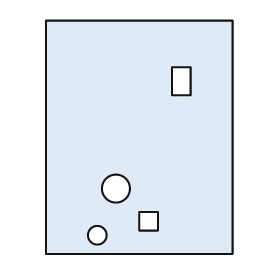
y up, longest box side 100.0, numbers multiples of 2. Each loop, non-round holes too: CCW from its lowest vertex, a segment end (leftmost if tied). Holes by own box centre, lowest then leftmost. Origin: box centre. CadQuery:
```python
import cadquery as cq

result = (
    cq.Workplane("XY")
    .moveTo(-40.0, -50.0)
    .lineTo(40.0, -50.0)
    .lineTo(40.0, 50.0)
    .lineTo(-40.0, 50.0)
    .close()
    .moveTo(-18.0, -42.0)
    .circle(4.0)
    .moveTo(0.0, -40.0)
    .lineTo(8.0, -40.0)
    .lineTo(8.0, -32.0)
    .lineTo(0.0, -32.0)
    .close()
    .moveTo(-10.0, -22.0)
    .circle(6.0)
    .moveTo(14.0, 18.0)
    .lineTo(22.0, 18.0)
    .lineTo(22.0, 30.0)
    .lineTo(14.0, 30.0)
    .close()
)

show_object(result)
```